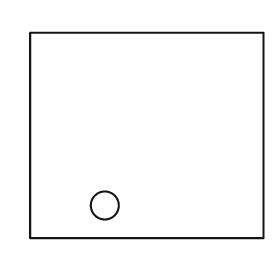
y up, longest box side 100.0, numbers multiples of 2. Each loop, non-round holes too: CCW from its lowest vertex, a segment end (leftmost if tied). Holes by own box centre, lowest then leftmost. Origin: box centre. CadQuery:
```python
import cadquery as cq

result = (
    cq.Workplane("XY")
    .moveTo(-50.0, -44.0)
    .lineTo(50.0, -44.0)
    .lineTo(50.0, 44.0)
    .lineTo(-50.0, 44.0)
    .close()
    .moveTo(-18.0, -30.0)
    .circle(6.0)
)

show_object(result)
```